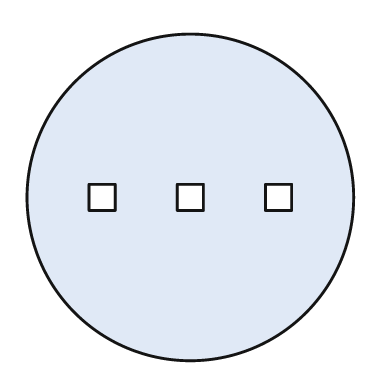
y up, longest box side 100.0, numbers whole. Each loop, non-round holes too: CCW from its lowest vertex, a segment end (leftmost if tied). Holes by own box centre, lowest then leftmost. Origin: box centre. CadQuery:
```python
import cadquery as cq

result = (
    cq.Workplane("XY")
    .moveTo(0.0, 0.0)
    .circle(50.0)
    .moveTo(-31.0, -4.0)
    .lineTo(-23.0, -4.0)
    .lineTo(-23.0, 4.0)
    .lineTo(-31.0, 4.0)
    .close()
    .moveTo(-4.0, -4.0)
    .lineTo(4.0, -4.0)
    .lineTo(4.0, 4.0)
    .lineTo(-4.0, 4.0)
    .close()
    .moveTo(23.0, -4.0)
    .lineTo(31.0, -4.0)
    .lineTo(31.0, 4.0)
    .lineTo(23.0, 4.0)
    .close()
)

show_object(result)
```